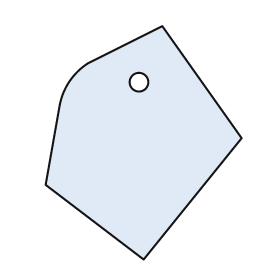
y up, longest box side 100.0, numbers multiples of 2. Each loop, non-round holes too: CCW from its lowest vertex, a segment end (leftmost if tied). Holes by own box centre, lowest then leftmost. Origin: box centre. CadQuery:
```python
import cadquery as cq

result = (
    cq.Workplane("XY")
    .moveTo(0.0, -50.0)
    .lineTo(42.0, 2.0)
    .lineTo(8.0, 50.0)
    .lineTo(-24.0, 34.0)
    .threePointArc((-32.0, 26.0), (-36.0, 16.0))
    .lineTo(-42.0, -18.0)
    .close()
    .moveTo(-2.0, 26.0)
    .circle(4.0)
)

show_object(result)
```